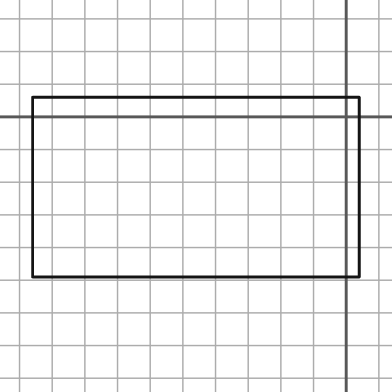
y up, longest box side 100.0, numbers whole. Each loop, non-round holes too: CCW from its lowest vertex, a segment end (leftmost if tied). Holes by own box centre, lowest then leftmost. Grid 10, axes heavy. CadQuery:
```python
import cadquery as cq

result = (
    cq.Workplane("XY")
    .moveTo(-96.0, -49.0)
    .lineTo(4.0, -49.0)
    .lineTo(4.0, 6.0)
    .lineTo(-96.0, 6.0)
    .close()
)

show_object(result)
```